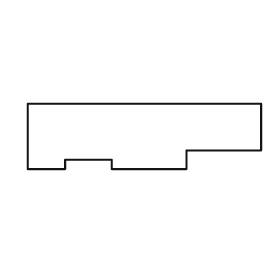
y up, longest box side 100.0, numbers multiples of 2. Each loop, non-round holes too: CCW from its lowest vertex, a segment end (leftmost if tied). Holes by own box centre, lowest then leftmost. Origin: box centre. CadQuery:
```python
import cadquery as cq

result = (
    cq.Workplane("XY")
    .moveTo(-50.0, -14.0)
    .lineTo(-34.0, -14.0)
    .lineTo(-34.0, -10.0)
    .lineTo(-14.0, -10.0)
    .lineTo(-14.0, -14.0)
    .lineTo(18.0, -14.0)
    .lineTo(18.0, -6.0)
    .lineTo(50.0, -6.0)
    .lineTo(50.0, 14.0)
    .lineTo(-50.0, 14.0)
    .close()
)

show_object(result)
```